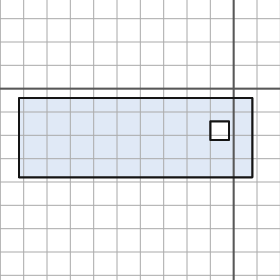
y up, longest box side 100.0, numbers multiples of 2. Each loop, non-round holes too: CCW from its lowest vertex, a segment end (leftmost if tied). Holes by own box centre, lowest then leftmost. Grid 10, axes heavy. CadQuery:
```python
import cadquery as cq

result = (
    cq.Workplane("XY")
    .moveTo(-92.0, -38.0)
    .lineTo(8.0, -38.0)
    .lineTo(8.0, -4.0)
    .lineTo(-92.0, -4.0)
    .close()
    .moveTo(-10.0, -22.0)
    .lineTo(-2.0, -22.0)
    .lineTo(-2.0, -14.0)
    .lineTo(-10.0, -14.0)
    .close()
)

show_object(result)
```